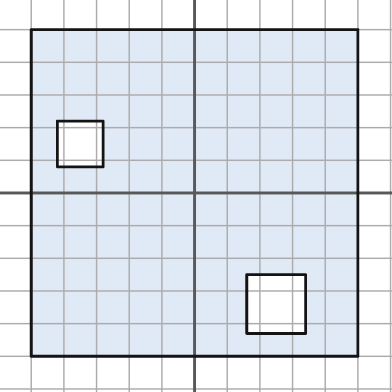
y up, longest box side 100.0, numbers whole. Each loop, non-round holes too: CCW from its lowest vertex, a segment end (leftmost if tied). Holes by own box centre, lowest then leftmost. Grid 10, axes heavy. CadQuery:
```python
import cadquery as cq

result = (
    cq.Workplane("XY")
    .moveTo(-50.0, -50.0)
    .lineTo(50.0, -50.0)
    .lineTo(50.0, 50.0)
    .lineTo(-50.0, 50.0)
    .close()
    .moveTo(16.0, -43.0)
    .lineTo(34.0, -43.0)
    .lineTo(34.0, -25.0)
    .lineTo(16.0, -25.0)
    .close()
    .moveTo(-42.0, 8.0)
    .lineTo(-28.0, 8.0)
    .lineTo(-28.0, 22.0)
    .lineTo(-42.0, 22.0)
    .close()
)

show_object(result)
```